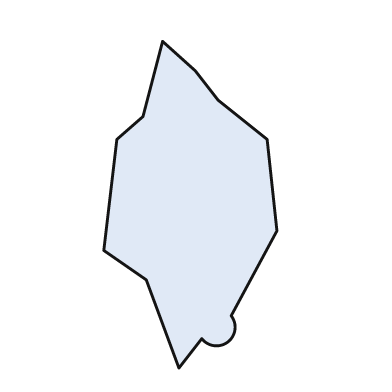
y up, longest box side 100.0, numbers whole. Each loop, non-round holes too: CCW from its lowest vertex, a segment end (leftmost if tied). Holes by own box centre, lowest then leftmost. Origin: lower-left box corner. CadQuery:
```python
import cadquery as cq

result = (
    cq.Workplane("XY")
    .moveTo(23.0, 0.0)
    .lineTo(30.0, 9.0)
    .threePointArc((38.0, 8.0), (39.0, 16.0))
    .lineTo(53.0, 42.0)
    .lineTo(50.0, 70.0)
    .lineTo(35.0, 82.0)
    .lineTo(28.0, 91.0)
    .lineTo(18.0, 100.0)
    .lineTo(12.0, 77.0)
    .lineTo(4.0, 70.0)
    .lineTo(0.0, 36.0)
    .lineTo(13.0, 27.0)
    .close()
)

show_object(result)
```